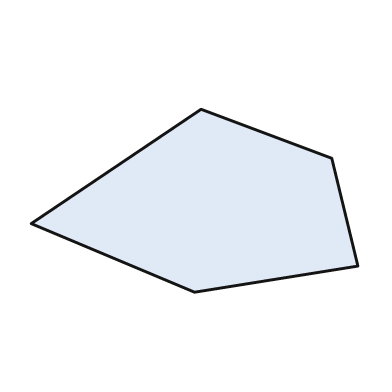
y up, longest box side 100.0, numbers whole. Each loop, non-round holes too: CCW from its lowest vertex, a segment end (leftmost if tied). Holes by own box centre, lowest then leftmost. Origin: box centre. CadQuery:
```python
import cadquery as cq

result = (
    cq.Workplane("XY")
    .moveTo(0.0, -28.0)
    .lineTo(50.0, -20.0)
    .lineTo(42.0, 13.0)
    .lineTo(2.0, 28.0)
    .lineTo(-50.0, -7.0)
    .close()
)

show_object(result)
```